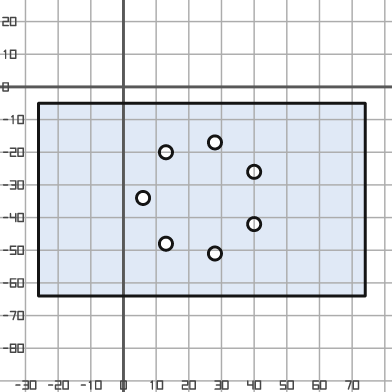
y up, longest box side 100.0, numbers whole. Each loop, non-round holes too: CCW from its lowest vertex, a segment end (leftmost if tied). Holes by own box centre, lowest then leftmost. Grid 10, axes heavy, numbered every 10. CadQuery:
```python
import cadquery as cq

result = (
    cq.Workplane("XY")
    .moveTo(-26.0, -64.0)
    .lineTo(74.0, -64.0)
    .lineTo(74.0, -5.0)
    .lineTo(-26.0, -5.0)
    .close()
    .moveTo(28.0, -51.0)
    .circle(2.0)
    .moveTo(13.0, -48.0)
    .circle(2.0)
    .moveTo(40.0, -42.0)
    .circle(2.0)
    .moveTo(6.0, -34.0)
    .circle(2.0)
    .moveTo(40.0, -26.0)
    .circle(2.0)
    .moveTo(13.0, -20.0)
    .circle(2.0)
    .moveTo(28.0, -17.0)
    .circle(2.0)
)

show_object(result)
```